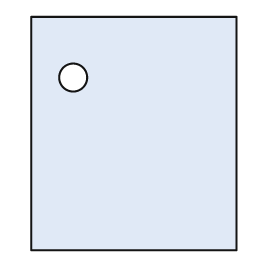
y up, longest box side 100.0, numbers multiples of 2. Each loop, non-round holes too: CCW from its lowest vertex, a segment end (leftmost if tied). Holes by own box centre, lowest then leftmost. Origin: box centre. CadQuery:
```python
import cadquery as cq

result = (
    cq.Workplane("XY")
    .moveTo(-44.0, -50.0)
    .lineTo(44.0, -50.0)
    .lineTo(44.0, 50.0)
    .lineTo(-44.0, 50.0)
    .close()
    .moveTo(-26.0, 24.0)
    .circle(6.0)
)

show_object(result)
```